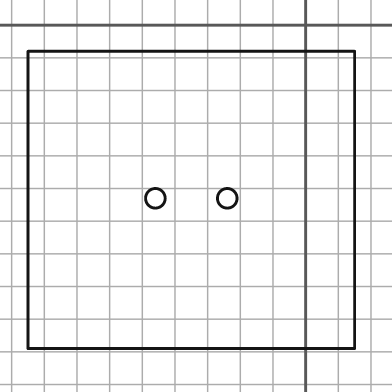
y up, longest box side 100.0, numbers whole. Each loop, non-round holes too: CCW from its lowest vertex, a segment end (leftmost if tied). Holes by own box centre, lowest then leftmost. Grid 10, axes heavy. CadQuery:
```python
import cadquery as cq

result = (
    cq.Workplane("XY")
    .moveTo(-85.0, -99.0)
    .lineTo(15.0, -99.0)
    .lineTo(15.0, -8.0)
    .lineTo(-85.0, -8.0)
    .close()
    .moveTo(-46.0, -53.0)
    .circle(3.0)
    .moveTo(-24.0, -53.0)
    .circle(3.0)
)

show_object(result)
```